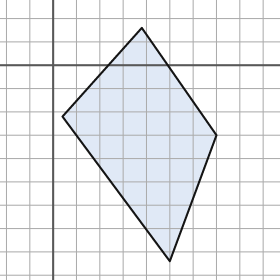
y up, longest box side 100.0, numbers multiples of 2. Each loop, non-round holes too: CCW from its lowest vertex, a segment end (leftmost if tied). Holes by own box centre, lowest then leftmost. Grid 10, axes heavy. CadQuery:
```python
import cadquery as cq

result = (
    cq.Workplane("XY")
    .moveTo(50.0, -84.0)
    .lineTo(70.0, -30.0)
    .lineTo(38.0, 16.0)
    .lineTo(4.0, -22.0)
    .close()
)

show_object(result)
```